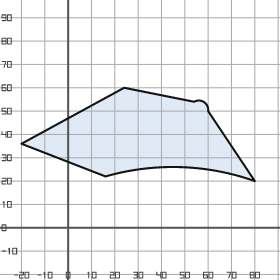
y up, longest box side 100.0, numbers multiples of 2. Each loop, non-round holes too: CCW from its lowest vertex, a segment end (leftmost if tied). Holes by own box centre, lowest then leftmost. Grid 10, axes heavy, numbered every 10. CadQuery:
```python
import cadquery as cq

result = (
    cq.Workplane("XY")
    .moveTo(80.0, 20.0)
    .lineTo(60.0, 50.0)
    .threePointArc((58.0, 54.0), (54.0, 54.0))
    .lineTo(24.0, 60.0)
    .lineTo(-20.0, 36.0)
    .lineTo(16.0, 22.0)
    .threePointArc((48.0, 26.0), (80.0, 20.0))
    .close()
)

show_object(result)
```